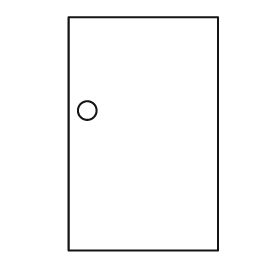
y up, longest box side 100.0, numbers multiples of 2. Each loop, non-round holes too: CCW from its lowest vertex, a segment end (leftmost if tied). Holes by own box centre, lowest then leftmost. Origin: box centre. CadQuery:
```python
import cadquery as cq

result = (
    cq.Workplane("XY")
    .moveTo(-32.0, -50.0)
    .lineTo(32.0, -50.0)
    .lineTo(32.0, 50.0)
    .lineTo(-32.0, 50.0)
    .close()
    .moveTo(-24.0, 10.0)
    .circle(4.0)
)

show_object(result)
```